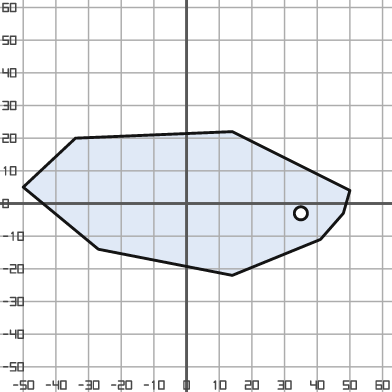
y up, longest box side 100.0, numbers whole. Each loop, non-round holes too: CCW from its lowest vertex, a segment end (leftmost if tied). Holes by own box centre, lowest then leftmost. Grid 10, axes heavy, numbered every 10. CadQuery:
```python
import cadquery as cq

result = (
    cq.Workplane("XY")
    .moveTo(14.0, -22.0)
    .lineTo(41.0, -11.0)
    .lineTo(48.0, -3.0)
    .lineTo(50.0, 4.0)
    .lineTo(14.0, 22.0)
    .lineTo(-34.0, 20.0)
    .lineTo(-50.0, 5.0)
    .lineTo(-27.0, -14.0)
    .close()
    .moveTo(35.0, -3.0)
    .circle(2.0)
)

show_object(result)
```